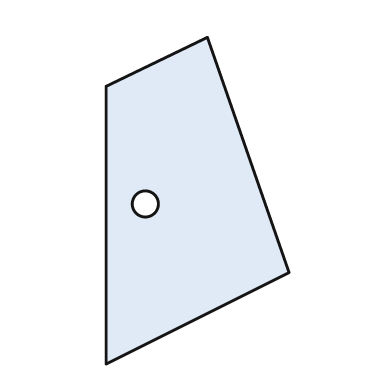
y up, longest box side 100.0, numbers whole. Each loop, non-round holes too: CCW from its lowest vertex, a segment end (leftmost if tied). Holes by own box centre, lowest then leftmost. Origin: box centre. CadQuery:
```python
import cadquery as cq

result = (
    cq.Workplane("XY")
    .moveTo(-28.0, -50.0)
    .lineTo(28.0, -22.0)
    .lineTo(3.0, 50.0)
    .lineTo(-28.0, 35.0)
    .close()
    .moveTo(-16.0, -1.0)
    .circle(4.0)
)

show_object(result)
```